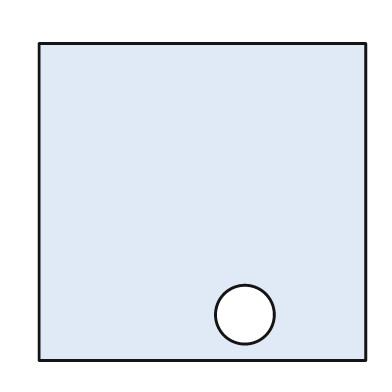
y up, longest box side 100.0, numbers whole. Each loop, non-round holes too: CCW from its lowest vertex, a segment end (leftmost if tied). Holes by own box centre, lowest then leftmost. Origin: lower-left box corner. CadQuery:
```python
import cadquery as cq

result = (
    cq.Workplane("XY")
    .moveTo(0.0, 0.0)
    .lineTo(100.0, 0.0)
    .lineTo(100.0, 97.0)
    .lineTo(0.0, 97.0)
    .close()
    .moveTo(63.0, 14.0)
    .circle(9.0)
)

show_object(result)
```